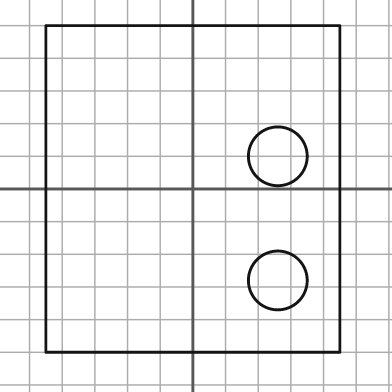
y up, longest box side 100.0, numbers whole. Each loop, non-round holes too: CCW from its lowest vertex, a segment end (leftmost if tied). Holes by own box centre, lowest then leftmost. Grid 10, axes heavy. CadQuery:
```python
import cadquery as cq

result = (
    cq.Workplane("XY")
    .moveTo(-45.0, -50.0)
    .lineTo(45.0, -50.0)
    .lineTo(45.0, 50.0)
    .lineTo(-45.0, 50.0)
    .close()
    .moveTo(26.0, -28.0)
    .circle(9.0)
    .moveTo(26.0, 10.0)
    .circle(9.0)
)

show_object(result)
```